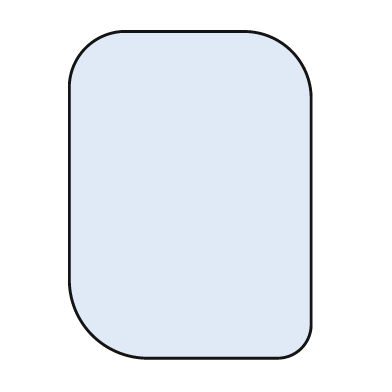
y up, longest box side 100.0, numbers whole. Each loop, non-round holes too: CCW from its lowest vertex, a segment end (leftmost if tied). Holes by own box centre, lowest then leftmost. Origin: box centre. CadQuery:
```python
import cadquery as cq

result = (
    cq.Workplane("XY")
    .moveTo(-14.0, -50.0)
    .lineTo(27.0, -50.0)
    .threePointArc((34.0, -47.0), (37.0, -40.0))
    .lineTo(37.0, 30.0)
    .threePointArc((31.0, 44.0), (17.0, 50.0))
    .lineTo(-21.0, 50.0)
    .threePointArc((-32.0, 45.0), (-37.0, 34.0))
    .lineTo(-37.0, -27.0)
    .threePointArc((-30.0, -43.0), (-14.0, -50.0))
    .close()
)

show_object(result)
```